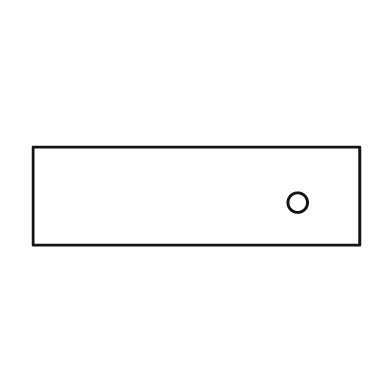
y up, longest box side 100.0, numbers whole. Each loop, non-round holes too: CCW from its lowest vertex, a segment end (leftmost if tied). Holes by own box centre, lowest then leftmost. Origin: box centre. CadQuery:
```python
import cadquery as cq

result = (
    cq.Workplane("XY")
    .moveTo(-50.0, -15.0)
    .lineTo(50.0, -15.0)
    .lineTo(50.0, 15.0)
    .lineTo(-50.0, 15.0)
    .close()
    .moveTo(31.0, -2.0)
    .circle(3.0)
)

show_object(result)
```